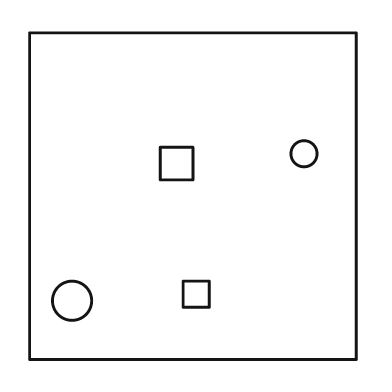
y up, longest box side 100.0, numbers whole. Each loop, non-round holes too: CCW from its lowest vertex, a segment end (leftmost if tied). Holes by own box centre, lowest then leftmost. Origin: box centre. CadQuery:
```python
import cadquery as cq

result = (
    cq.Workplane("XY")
    .moveTo(-50.0, -50.0)
    .lineTo(50.0, -50.0)
    .lineTo(50.0, 50.0)
    .lineTo(-50.0, 50.0)
    .close()
    .moveTo(-37.0, -32.0)
    .circle(6.0)
    .moveTo(-3.0, -34.0)
    .lineTo(5.0, -34.0)
    .lineTo(5.0, -26.0)
    .lineTo(-3.0, -26.0)
    .close()
    .moveTo(-10.0, 5.0)
    .lineTo(0.0, 5.0)
    .lineTo(0.0, 15.0)
    .lineTo(-10.0, 15.0)
    .close()
    .moveTo(34.0, 13.0)
    .circle(4.0)
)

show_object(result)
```